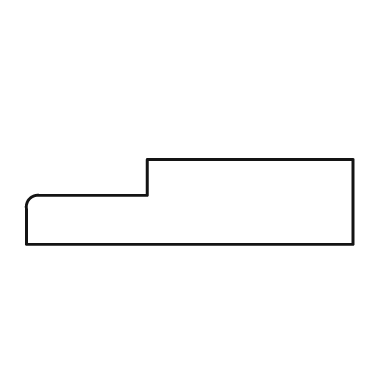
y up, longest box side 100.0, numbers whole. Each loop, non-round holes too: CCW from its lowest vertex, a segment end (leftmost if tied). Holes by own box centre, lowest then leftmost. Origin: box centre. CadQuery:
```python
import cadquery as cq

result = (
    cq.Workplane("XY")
    .moveTo(-50.0, -13.0)
    .lineTo(50.0, -13.0)
    .lineTo(50.0, 13.0)
    .lineTo(-13.0, 13.0)
    .lineTo(-13.0, 2.0)
    .lineTo(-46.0, 2.0)
    .threePointArc((-49.0, 1.0), (-50.0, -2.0))
    .close()
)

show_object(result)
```